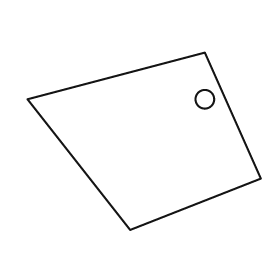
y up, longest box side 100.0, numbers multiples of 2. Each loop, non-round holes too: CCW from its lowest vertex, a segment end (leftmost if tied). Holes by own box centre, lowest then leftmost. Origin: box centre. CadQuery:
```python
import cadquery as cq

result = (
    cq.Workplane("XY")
    .moveTo(-6.0, -38.0)
    .lineTo(50.0, -16.0)
    .lineTo(26.0, 38.0)
    .lineTo(-50.0, 18.0)
    .close()
    .moveTo(26.0, 18.0)
    .circle(4.0)
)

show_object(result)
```